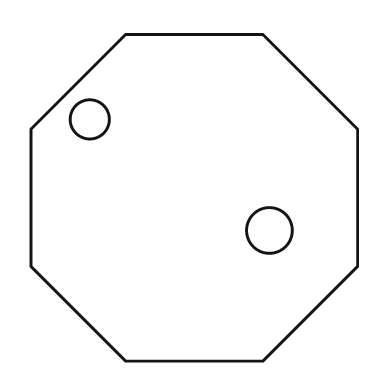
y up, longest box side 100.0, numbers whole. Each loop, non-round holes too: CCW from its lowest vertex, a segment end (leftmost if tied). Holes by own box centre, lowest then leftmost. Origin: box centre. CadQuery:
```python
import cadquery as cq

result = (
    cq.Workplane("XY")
    .moveTo(-21.0, -50.0)
    .lineTo(21.0, -50.0)
    .lineTo(50.0, -21.0)
    .lineTo(50.0, 21.0)
    .lineTo(21.0, 50.0)
    .lineTo(-21.0, 50.0)
    .lineTo(-50.0, 21.0)
    .lineTo(-50.0, -21.0)
    .close()
    .moveTo(23.0, -10.0)
    .circle(7.0)
    .moveTo(-32.0, 24.0)
    .circle(6.0)
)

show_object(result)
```